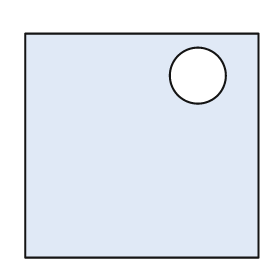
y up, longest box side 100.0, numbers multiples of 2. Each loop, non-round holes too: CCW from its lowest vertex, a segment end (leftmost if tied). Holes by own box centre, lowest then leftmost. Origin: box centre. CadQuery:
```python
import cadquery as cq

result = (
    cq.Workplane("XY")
    .moveTo(-50.0, -48.0)
    .lineTo(50.0, -48.0)
    .lineTo(50.0, 48.0)
    .lineTo(-50.0, 48.0)
    .close()
    .moveTo(24.0, 30.0)
    .circle(12.0)
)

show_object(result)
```